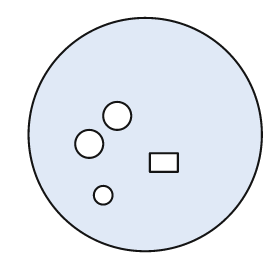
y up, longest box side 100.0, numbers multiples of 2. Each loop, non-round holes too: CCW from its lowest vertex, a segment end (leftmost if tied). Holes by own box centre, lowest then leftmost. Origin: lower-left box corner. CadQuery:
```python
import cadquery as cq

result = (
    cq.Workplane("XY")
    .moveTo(50.0, 50.0)
    .circle(50.0)
    .moveTo(32.0, 24.0)
    .circle(4.0)
    .moveTo(52.0, 34.0)
    .lineTo(64.0, 34.0)
    .lineTo(64.0, 42.0)
    .lineTo(52.0, 42.0)
    .close()
    .moveTo(26.0, 46.0)
    .circle(6.0)
    .moveTo(38.0, 58.0)
    .circle(6.0)
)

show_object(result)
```